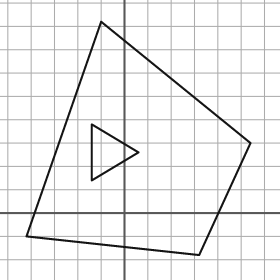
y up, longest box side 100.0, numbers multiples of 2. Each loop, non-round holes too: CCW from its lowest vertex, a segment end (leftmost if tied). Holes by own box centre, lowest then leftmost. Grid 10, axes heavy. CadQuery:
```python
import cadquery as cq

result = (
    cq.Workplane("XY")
    .moveTo(32.0, -18.0)
    .lineTo(54.0, 30.0)
    .lineTo(-10.0, 82.0)
    .lineTo(-42.0, -10.0)
    .close()
    .moveTo(-14.0, 14.0)
    .lineTo(6.0, 26.0)
    .lineTo(-14.0, 38.0)
    .close()
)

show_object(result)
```